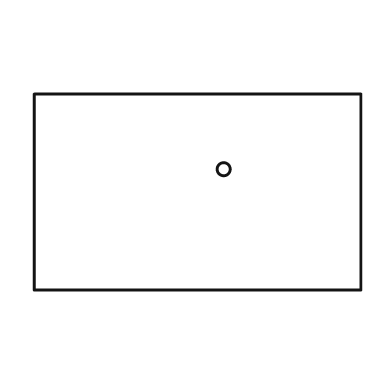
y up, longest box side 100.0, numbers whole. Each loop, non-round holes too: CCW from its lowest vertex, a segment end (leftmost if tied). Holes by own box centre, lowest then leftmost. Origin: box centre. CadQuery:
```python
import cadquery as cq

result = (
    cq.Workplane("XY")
    .moveTo(-50.0, -30.0)
    .lineTo(50.0, -30.0)
    .lineTo(50.0, 30.0)
    .lineTo(-50.0, 30.0)
    .close()
    .moveTo(8.0, 7.0)
    .circle(2.0)
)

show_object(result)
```